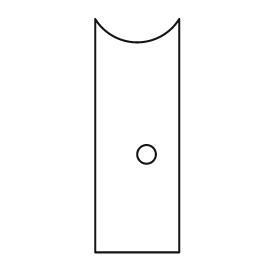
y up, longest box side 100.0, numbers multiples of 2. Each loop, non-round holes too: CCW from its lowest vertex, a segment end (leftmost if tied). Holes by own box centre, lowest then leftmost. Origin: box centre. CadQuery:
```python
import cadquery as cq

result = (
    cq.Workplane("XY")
    .moveTo(-18.0, -50.0)
    .lineTo(18.0, -50.0)
    .lineTo(18.0, 50.0)
    .threePointArc((0.0, 40.0), (-18.0, 50.0))
    .close()
    .moveTo(4.0, -8.0)
    .circle(4.0)
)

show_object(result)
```